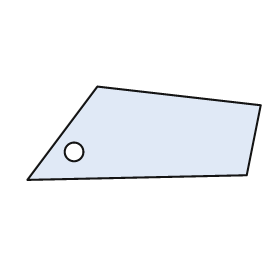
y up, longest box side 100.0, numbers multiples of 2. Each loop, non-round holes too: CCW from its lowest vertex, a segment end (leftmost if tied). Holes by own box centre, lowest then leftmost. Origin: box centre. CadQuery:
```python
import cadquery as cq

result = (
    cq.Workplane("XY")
    .moveTo(-50.0, -20.0)
    .lineTo(44.0, -18.0)
    .lineTo(50.0, 12.0)
    .lineTo(-20.0, 20.0)
    .close()
    .moveTo(-30.0, -8.0)
    .circle(4.0)
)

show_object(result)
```